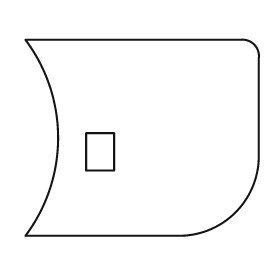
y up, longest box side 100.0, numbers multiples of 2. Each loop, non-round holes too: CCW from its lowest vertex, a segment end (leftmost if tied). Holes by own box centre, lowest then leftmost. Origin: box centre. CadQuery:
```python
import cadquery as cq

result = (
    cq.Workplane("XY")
    .moveTo(-50.0, -42.0)
    .lineTo(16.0, -42.0)
    .threePointArc((40.0, -32.0), (50.0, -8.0))
    .lineTo(50.0, 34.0)
    .threePointArc((48.0, 40.0), (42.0, 42.0))
    .lineTo(-50.0, 42.0)
    .threePointArc((-36.0, 0.0), (-50.0, -42.0))
    .close()
    .moveTo(-24.0, -14.0)
    .lineTo(-12.0, -14.0)
    .lineTo(-12.0, 2.0)
    .lineTo(-24.0, 2.0)
    .close()
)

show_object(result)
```